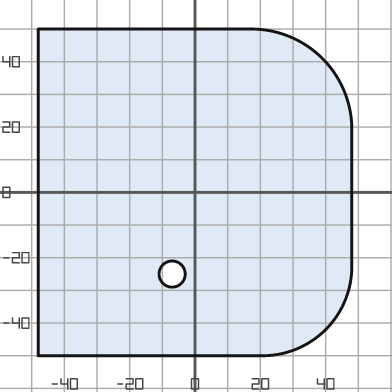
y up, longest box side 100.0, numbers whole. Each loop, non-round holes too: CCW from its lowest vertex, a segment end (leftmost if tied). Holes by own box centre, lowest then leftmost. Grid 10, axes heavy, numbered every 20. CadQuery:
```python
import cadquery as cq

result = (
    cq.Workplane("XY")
    .moveTo(-48.0, -50.0)
    .lineTo(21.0, -50.0)
    .threePointArc((40.0, -42.0), (48.0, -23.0))
    .lineTo(48.0, 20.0)
    .threePointArc((39.0, 41.0), (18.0, 50.0))
    .lineTo(-48.0, 50.0)
    .close()
    .moveTo(-7.0, -25.0)
    .circle(4.0)
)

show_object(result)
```